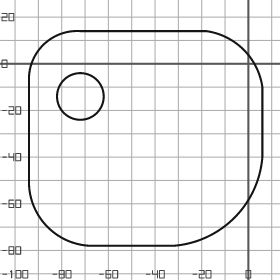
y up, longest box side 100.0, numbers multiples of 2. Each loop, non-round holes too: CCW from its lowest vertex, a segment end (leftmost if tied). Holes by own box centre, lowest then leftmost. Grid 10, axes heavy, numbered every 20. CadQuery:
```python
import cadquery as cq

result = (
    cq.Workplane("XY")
    .moveTo(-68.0, -78.0)
    .lineTo(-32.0, -78.0)
    .threePointArc((-6.0, -66.0), (6.0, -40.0))
    .lineTo(6.0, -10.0)
    .threePointArc((-2.0, 6.0), (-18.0, 14.0))
    .lineTo(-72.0, 14.0)
    .threePointArc((-88.0, 8.0), (-94.0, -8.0))
    .lineTo(-94.0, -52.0)
    .threePointArc((-86.0, -70.0), (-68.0, -78.0))
    .close()
    .moveTo(-72.0, -14.0)
    .circle(10.0)
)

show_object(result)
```